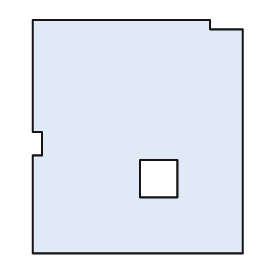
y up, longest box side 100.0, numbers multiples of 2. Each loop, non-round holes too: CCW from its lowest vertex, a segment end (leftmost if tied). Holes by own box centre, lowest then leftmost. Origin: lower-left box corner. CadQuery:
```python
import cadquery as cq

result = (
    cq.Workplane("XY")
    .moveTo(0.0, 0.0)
    .lineTo(90.0, 0.0)
    .lineTo(90.0, 96.0)
    .lineTo(76.0, 96.0)
    .lineTo(76.0, 100.0)
    .lineTo(0.0, 100.0)
    .lineTo(0.0, 52.0)
    .lineTo(4.0, 52.0)
    .lineTo(4.0, 42.0)
    .lineTo(0.0, 42.0)
    .close()
    .moveTo(46.0, 24.0)
    .lineTo(62.0, 24.0)
    .lineTo(62.0, 40.0)
    .lineTo(46.0, 40.0)
    .close()
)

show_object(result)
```